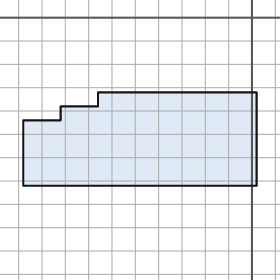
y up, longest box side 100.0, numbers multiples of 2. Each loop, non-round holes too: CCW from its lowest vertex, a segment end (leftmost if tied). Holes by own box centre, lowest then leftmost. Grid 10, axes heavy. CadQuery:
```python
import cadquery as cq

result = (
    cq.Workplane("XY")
    .moveTo(-98.0, -72.0)
    .lineTo(2.0, -72.0)
    .lineTo(2.0, -32.0)
    .lineTo(-66.0, -32.0)
    .lineTo(-66.0, -38.0)
    .lineTo(-82.0, -38.0)
    .lineTo(-82.0, -44.0)
    .lineTo(-98.0, -44.0)
    .close()
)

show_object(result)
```